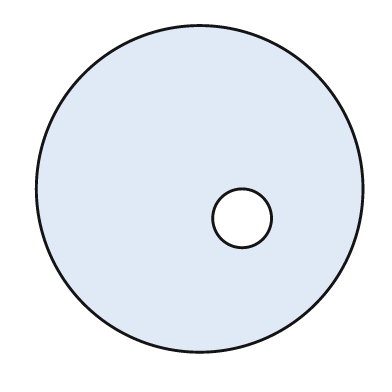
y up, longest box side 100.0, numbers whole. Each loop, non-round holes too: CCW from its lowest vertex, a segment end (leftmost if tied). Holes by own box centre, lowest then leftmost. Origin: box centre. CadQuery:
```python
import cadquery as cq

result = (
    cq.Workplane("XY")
    .moveTo(0.0, 0.0)
    .circle(50.0)
    .moveTo(13.0, -9.0)
    .circle(9.0)
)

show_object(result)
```